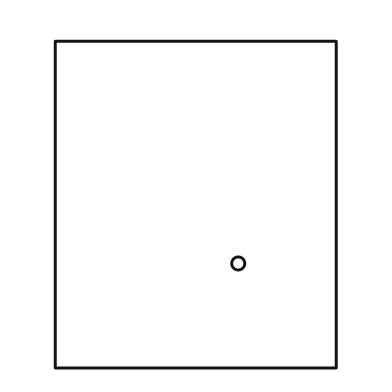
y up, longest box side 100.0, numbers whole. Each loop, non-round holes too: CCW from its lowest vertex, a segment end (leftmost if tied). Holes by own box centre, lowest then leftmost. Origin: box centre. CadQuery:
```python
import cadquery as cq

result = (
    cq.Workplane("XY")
    .moveTo(-43.0, -50.0)
    .lineTo(43.0, -50.0)
    .lineTo(43.0, 50.0)
    .lineTo(-43.0, 50.0)
    .close()
    .moveTo(13.0, -18.0)
    .circle(2.0)
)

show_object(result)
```